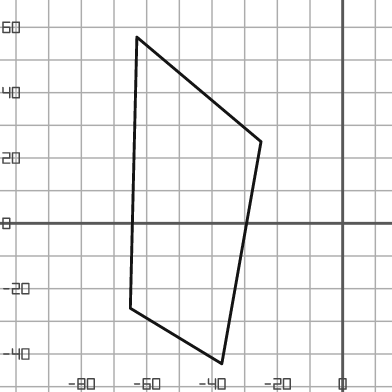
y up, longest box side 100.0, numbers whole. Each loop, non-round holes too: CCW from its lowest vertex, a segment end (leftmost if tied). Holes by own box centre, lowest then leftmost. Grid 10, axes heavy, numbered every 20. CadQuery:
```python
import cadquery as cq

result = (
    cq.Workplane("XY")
    .moveTo(-37.0, -43.0)
    .lineTo(-25.0, 25.0)
    .lineTo(-63.0, 57.0)
    .lineTo(-65.0, -26.0)
    .close()
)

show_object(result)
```